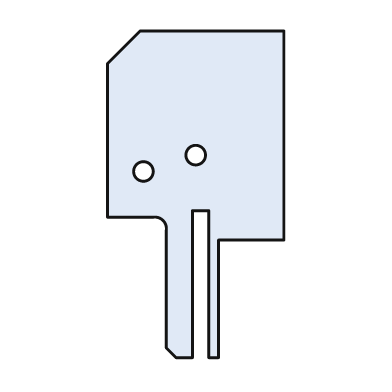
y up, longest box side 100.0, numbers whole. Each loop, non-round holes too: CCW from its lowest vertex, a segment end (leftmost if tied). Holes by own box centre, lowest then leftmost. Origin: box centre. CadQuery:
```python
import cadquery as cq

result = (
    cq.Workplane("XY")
    .moveTo(-6.0, -50.0)
    .lineTo(-1.0, -50.0)
    .lineTo(-1.0, -5.0)
    .lineTo(4.0, -5.0)
    .lineTo(4.0, -50.0)
    .lineTo(7.0, -50.0)
    .lineTo(7.0, -14.0)
    .lineTo(27.0, -14.0)
    .lineTo(27.0, 50.0)
    .lineTo(-17.0, 50.0)
    .lineTo(-27.0, 40.0)
    .lineTo(-27.0, -7.0)
    .lineTo(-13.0, -7.0)
    .threePointArc((-10.0, -8.0), (-9.0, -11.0))
    .lineTo(-9.0, -47.0)
    .close()
    .moveTo(-16.0, 7.0)
    .circle(3.0)
    .moveTo(0.0, 12.0)
    .circle(3.0)
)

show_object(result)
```